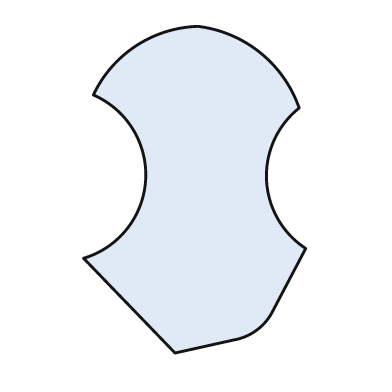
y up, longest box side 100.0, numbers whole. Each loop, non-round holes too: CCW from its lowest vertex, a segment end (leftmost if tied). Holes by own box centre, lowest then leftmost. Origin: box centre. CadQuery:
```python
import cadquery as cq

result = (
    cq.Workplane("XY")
    .moveTo(-6.0, -50.0)
    .lineTo(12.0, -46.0)
    .threePointArc((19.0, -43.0), (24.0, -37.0))
    .lineTo(34.0, -18.0)
    .threePointArc((22.0, 3.0), (32.0, 25.0))
    .threePointArc((20.0, 42.0), (1.0, 50.0))
    .threePointArc((-18.0, 44.0), (-31.0, 29.0))
    .threePointArc((-15.0, 3.0), (-34.0, -21.0))
    .close()
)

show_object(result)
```